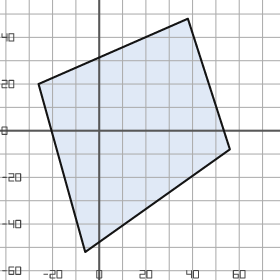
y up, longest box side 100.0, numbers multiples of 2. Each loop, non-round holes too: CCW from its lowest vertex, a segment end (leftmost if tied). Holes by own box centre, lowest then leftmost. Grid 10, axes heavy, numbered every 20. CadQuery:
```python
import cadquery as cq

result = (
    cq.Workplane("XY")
    .moveTo(-6.0, -52.0)
    .lineTo(56.0, -8.0)
    .lineTo(38.0, 48.0)
    .lineTo(-26.0, 20.0)
    .close()
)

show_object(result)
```